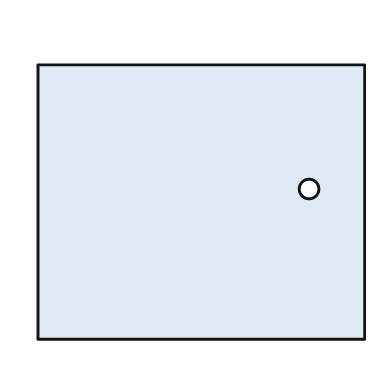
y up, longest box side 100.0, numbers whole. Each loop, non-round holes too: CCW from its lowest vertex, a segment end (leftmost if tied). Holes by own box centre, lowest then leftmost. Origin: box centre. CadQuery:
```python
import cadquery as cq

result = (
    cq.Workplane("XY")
    .moveTo(-50.0, -42.0)
    .lineTo(50.0, -42.0)
    .lineTo(50.0, 42.0)
    .lineTo(-50.0, 42.0)
    .close()
    .moveTo(33.0, 4.0)
    .circle(3.0)
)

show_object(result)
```